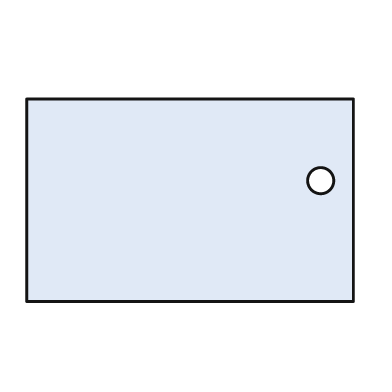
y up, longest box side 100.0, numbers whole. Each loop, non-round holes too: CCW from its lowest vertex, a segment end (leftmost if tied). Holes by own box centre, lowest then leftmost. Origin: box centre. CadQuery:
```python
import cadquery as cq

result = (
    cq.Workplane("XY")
    .moveTo(-50.0, -31.0)
    .lineTo(50.0, -31.0)
    .lineTo(50.0, 31.0)
    .lineTo(-50.0, 31.0)
    .close()
    .moveTo(40.0, 6.0)
    .circle(4.0)
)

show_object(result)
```